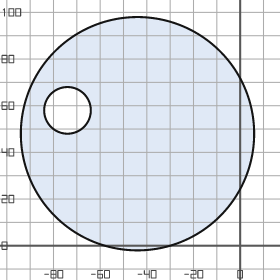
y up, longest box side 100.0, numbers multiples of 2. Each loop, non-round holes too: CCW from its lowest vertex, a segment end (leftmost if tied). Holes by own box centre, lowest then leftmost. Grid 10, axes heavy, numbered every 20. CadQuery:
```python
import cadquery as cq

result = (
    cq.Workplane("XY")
    .moveTo(-44.0, 48.0)
    .circle(50.0)
    .moveTo(-74.0, 58.0)
    .circle(10.0)
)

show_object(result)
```